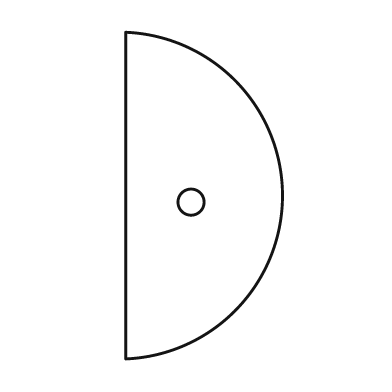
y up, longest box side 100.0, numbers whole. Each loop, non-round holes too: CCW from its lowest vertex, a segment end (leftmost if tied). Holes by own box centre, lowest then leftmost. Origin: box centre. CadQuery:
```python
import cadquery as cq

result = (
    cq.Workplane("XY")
    .moveTo(-24.0, -50.0)
    .threePointArc((24.0, 0.0), (-24.0, 50.0))
    .close()
    .moveTo(-4.0, -2.0)
    .circle(4.0)
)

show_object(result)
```